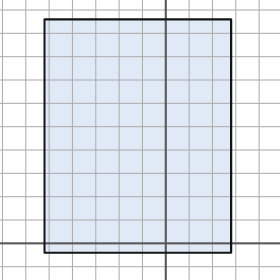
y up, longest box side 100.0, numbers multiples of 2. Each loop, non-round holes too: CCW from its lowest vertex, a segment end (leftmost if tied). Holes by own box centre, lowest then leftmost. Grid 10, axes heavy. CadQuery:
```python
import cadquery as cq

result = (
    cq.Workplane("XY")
    .moveTo(-52.0, -4.0)
    .lineTo(28.0, -4.0)
    .lineTo(28.0, 96.0)
    .lineTo(-52.0, 96.0)
    .close()
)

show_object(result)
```